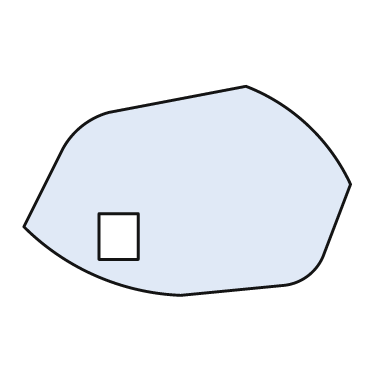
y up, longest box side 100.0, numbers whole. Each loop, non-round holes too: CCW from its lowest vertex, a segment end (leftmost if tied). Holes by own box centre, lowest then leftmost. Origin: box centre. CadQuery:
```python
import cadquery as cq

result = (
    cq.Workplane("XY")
    .moveTo(-2.0, -32.0)
    .lineTo(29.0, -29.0)
    .threePointArc((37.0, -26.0), (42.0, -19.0))
    .lineTo(50.0, 2.0)
    .threePointArc((37.0, 20.0), (18.0, 32.0))
    .lineTo(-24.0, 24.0)
    .threePointArc((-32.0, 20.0), (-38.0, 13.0))
    .lineTo(-50.0, -11.0)
    .threePointArc((-28.0, -26.0), (-2.0, -32.0))
    .close()
    .moveTo(-27.0, -21.0)
    .lineTo(-15.0, -21.0)
    .lineTo(-15.0, -7.0)
    .lineTo(-27.0, -7.0)
    .close()
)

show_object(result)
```